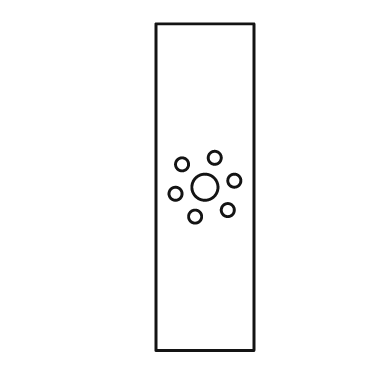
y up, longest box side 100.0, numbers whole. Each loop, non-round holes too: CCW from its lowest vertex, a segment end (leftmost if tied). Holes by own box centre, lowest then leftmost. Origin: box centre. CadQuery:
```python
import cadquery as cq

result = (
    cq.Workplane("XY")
    .moveTo(-15.0, -50.0)
    .lineTo(15.0, -50.0)
    .lineTo(15.0, 50.0)
    .lineTo(-15.0, 50.0)
    .close()
    .moveTo(-3.0, -9.0)
    .circle(2.0)
    .moveTo(7.0, -7.0)
    .circle(2.0)
    .moveTo(-9.0, -2.0)
    .circle(2.0)
    .moveTo(0.0, 0.0)
    .circle(4.0)
    .moveTo(9.0, 2.0)
    .circle(2.0)
    .moveTo(-7.0, 7.0)
    .circle(2.0)
    .moveTo(3.0, 9.0)
    .circle(2.0)
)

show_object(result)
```